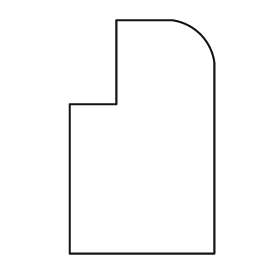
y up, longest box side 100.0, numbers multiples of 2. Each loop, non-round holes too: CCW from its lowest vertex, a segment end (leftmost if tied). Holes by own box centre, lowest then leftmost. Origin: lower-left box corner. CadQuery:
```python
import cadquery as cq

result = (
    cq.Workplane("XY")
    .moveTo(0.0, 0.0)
    .lineTo(62.0, 0.0)
    .lineTo(62.0, 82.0)
    .threePointArc((56.0, 94.0), (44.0, 100.0))
    .lineTo(20.0, 100.0)
    .lineTo(20.0, 64.0)
    .lineTo(0.0, 64.0)
    .close()
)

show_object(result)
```